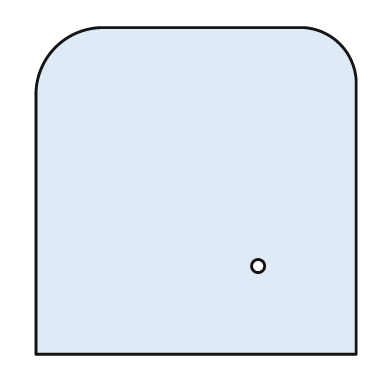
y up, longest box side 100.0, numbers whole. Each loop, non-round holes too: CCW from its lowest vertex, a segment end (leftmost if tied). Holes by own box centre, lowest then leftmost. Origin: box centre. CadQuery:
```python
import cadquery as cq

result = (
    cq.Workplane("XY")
    .moveTo(-49.0, -50.0)
    .lineTo(49.0, -50.0)
    .lineTo(49.0, 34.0)
    .threePointArc((44.0, 45.0), (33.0, 50.0))
    .lineTo(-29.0, 50.0)
    .threePointArc((-43.0, 44.0), (-49.0, 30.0))
    .close()
    .moveTo(19.0, -23.0)
    .circle(2.0)
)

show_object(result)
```